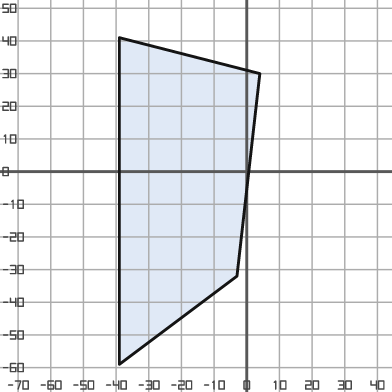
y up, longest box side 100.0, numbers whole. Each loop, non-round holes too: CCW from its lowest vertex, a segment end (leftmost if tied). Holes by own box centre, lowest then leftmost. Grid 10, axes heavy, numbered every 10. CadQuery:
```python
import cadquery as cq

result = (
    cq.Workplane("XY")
    .moveTo(-39.0, -59.0)
    .lineTo(-3.0, -32.0)
    .lineTo(4.0, 30.0)
    .lineTo(-39.0, 41.0)
    .close()
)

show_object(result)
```